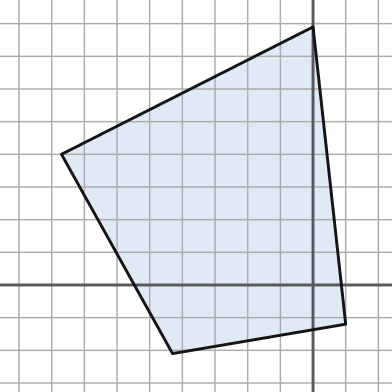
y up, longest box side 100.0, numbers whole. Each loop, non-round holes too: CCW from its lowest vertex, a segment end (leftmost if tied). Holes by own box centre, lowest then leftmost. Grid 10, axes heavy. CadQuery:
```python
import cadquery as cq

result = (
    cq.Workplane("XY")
    .moveTo(-43.0, -21.0)
    .lineTo(10.0, -12.0)
    .lineTo(0.0, 79.0)
    .lineTo(-77.0, 40.0)
    .close()
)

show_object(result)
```